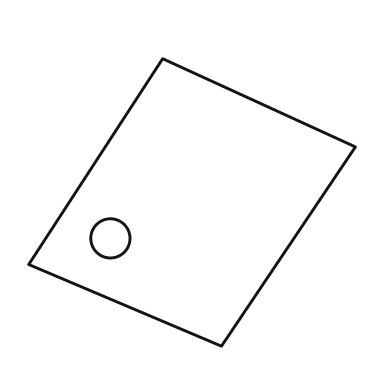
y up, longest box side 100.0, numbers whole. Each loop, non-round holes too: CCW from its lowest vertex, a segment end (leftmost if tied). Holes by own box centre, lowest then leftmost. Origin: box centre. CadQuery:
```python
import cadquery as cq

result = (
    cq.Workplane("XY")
    .moveTo(9.0, -44.0)
    .lineTo(50.0, 17.0)
    .lineTo(-9.0, 44.0)
    .lineTo(-50.0, -19.0)
    .close()
    .moveTo(-25.0, -11.0)
    .circle(6.0)
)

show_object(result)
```